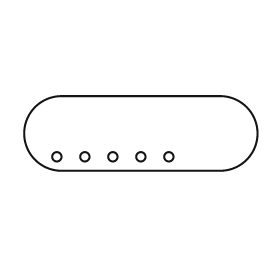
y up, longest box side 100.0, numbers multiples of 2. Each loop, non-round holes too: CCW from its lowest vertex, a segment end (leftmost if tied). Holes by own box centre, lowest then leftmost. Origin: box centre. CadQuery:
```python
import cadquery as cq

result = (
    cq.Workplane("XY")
    .moveTo(-34.0, -16.0)
    .lineTo(34.0, -16.0)
    .threePointArc((50.0, 0.0), (34.0, 16.0))
    .lineTo(-34.0, 16.0)
    .threePointArc((-50.0, 0.0), (-34.0, -16.0))
    .close()
    .moveTo(-36.0, -10.0)
    .circle(2.0)
    .moveTo(-24.0, -10.0)
    .circle(2.0)
    .moveTo(-12.0, -10.0)
    .circle(2.0)
    .moveTo(0.0, -10.0)
    .circle(2.0)
    .moveTo(12.0, -10.0)
    .circle(2.0)
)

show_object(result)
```